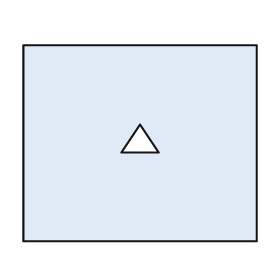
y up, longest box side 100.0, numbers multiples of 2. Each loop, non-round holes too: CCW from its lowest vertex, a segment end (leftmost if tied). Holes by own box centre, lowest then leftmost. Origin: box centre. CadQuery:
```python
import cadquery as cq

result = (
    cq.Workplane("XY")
    .moveTo(-50.0, -42.0)
    .lineTo(50.0, -42.0)
    .lineTo(50.0, 42.0)
    .lineTo(-50.0, 42.0)
    .close()
    .moveTo(-8.0, -4.0)
    .lineTo(8.0, -4.0)
    .lineTo(0.0, 8.0)
    .close()
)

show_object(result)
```